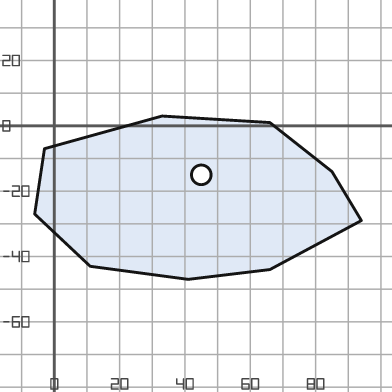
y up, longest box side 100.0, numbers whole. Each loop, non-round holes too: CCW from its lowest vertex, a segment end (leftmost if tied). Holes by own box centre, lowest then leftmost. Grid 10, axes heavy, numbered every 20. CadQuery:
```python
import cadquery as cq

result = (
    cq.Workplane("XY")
    .moveTo(41.0, -47.0)
    .lineTo(66.0, -44.0)
    .lineTo(94.0, -29.0)
    .lineTo(85.0, -14.0)
    .lineTo(66.0, 1.0)
    .lineTo(33.0, 3.0)
    .lineTo(-3.0, -7.0)
    .lineTo(-6.0, -27.0)
    .lineTo(11.0, -43.0)
    .close()
    .moveTo(45.0, -15.0)
    .circle(3.0)
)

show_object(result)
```